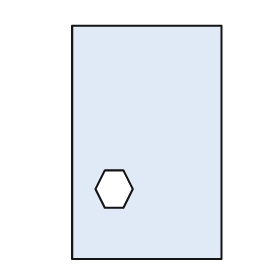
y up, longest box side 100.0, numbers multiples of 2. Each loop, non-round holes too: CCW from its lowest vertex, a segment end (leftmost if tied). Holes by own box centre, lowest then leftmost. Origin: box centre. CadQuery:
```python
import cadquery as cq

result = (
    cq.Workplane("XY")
    .moveTo(-32.0, -50.0)
    .lineTo(32.0, -50.0)
    .lineTo(32.0, 50.0)
    .lineTo(-32.0, 50.0)
    .close()
    .moveTo(-18.0, -28.0)
    .lineTo(-10.0, -28.0)
    .lineTo(-6.0, -20.0)
    .lineTo(-10.0, -12.0)
    .lineTo(-18.0, -12.0)
    .lineTo(-22.0, -20.0)
    .close()
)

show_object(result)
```